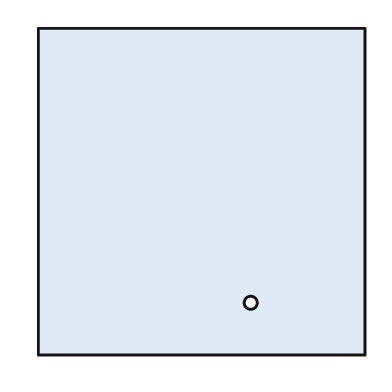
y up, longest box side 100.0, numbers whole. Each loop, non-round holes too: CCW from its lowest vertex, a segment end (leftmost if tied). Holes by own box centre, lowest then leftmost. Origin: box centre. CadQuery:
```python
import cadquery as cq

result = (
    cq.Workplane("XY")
    .moveTo(-50.0, -50.0)
    .lineTo(50.0, -50.0)
    .lineTo(50.0, 50.0)
    .lineTo(-50.0, 50.0)
    .close()
    .moveTo(15.0, -34.0)
    .circle(2.0)
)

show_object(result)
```